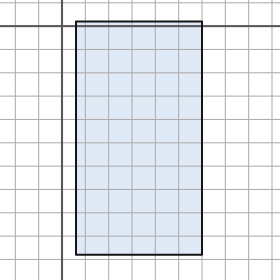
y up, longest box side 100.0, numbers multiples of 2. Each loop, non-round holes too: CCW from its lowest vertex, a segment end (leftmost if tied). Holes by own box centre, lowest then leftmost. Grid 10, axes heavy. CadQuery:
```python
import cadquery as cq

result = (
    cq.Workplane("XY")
    .moveTo(6.0, -98.0)
    .lineTo(60.0, -98.0)
    .lineTo(60.0, 2.0)
    .lineTo(6.0, 2.0)
    .close()
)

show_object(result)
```